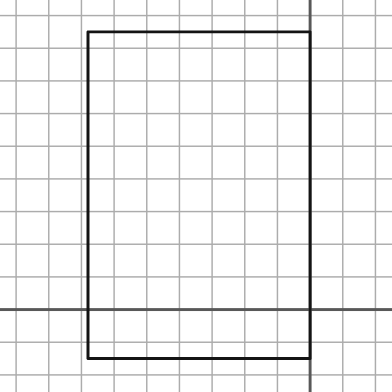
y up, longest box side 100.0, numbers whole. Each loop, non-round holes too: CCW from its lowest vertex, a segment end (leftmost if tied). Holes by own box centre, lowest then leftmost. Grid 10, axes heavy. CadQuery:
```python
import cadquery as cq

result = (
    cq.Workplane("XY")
    .moveTo(-68.0, -15.0)
    .lineTo(0.0, -15.0)
    .lineTo(0.0, 85.0)
    .lineTo(-68.0, 85.0)
    .close()
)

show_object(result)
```